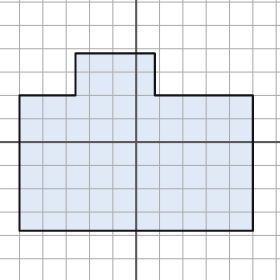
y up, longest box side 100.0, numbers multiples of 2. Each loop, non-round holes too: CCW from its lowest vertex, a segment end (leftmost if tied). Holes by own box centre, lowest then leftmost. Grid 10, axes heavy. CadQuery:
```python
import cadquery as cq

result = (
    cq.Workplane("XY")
    .moveTo(-50.0, -38.0)
    .lineTo(50.0, -38.0)
    .lineTo(50.0, 20.0)
    .lineTo(8.0, 20.0)
    .lineTo(8.0, 38.0)
    .lineTo(-26.0, 38.0)
    .lineTo(-26.0, 20.0)
    .lineTo(-50.0, 20.0)
    .close()
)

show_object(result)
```